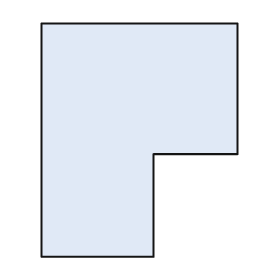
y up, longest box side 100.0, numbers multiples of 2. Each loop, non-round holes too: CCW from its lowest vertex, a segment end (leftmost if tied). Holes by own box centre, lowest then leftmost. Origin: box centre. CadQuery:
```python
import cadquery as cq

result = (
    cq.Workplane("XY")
    .moveTo(-42.0, -50.0)
    .lineTo(6.0, -50.0)
    .lineTo(6.0, -6.0)
    .lineTo(42.0, -6.0)
    .lineTo(42.0, 50.0)
    .lineTo(-42.0, 50.0)
    .close()
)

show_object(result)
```